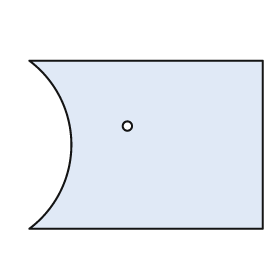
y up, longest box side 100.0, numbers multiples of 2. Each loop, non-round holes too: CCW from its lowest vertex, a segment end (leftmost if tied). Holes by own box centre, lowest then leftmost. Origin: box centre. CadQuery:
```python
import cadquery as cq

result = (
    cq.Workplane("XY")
    .moveTo(-50.0, -36.0)
    .lineTo(50.0, -36.0)
    .lineTo(50.0, 36.0)
    .lineTo(-50.0, 36.0)
    .threePointArc((-32.0, 0.0), (-50.0, -36.0))
    .close()
    .moveTo(-8.0, 8.0)
    .circle(2.0)
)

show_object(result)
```